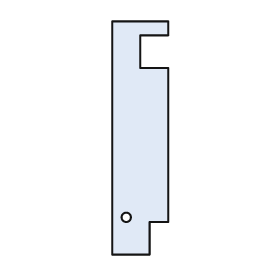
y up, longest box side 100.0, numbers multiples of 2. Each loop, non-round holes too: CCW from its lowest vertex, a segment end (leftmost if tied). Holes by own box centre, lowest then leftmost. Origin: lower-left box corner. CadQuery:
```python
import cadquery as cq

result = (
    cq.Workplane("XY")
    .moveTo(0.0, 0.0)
    .lineTo(16.0, 0.0)
    .lineTo(16.0, 14.0)
    .lineTo(24.0, 14.0)
    .lineTo(24.0, 80.0)
    .lineTo(12.0, 80.0)
    .lineTo(12.0, 94.0)
    .lineTo(24.0, 94.0)
    .lineTo(24.0, 100.0)
    .lineTo(0.0, 100.0)
    .close()
    .moveTo(6.0, 16.0)
    .circle(2.0)
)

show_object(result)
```